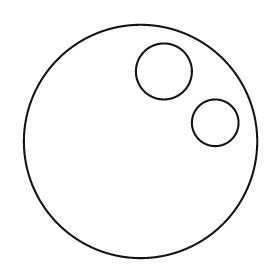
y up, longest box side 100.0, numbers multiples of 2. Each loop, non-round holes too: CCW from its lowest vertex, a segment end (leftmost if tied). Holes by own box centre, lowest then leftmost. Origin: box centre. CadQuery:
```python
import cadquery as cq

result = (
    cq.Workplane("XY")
    .moveTo(0.0, 0.0)
    .circle(50.0)
    .moveTo(32.0, 8.0)
    .circle(10.0)
    .moveTo(10.0, 30.0)
    .circle(12.0)
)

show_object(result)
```